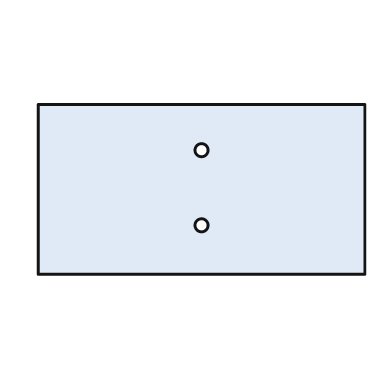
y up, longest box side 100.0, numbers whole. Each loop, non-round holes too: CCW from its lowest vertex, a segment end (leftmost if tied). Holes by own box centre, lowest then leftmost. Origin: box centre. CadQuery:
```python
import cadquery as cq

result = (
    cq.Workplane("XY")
    .moveTo(-50.0, -26.0)
    .lineTo(50.0, -26.0)
    .lineTo(50.0, 26.0)
    .lineTo(-50.0, 26.0)
    .close()
    .moveTo(0.0, -11.0)
    .circle(2.0)
    .moveTo(0.0, 12.0)
    .circle(2.0)
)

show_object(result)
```